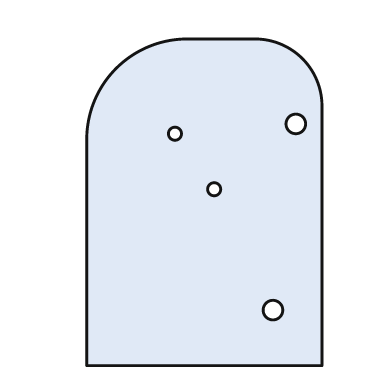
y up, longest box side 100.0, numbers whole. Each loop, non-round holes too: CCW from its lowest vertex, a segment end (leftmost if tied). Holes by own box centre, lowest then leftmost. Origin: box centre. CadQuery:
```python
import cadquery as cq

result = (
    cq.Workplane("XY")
    .moveTo(-36.0, -50.0)
    .lineTo(36.0, -50.0)
    .lineTo(36.0, 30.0)
    .threePointArc((30.0, 44.0), (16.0, 50.0))
    .lineTo(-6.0, 50.0)
    .threePointArc((-27.0, 41.0), (-36.0, 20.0))
    .close()
    .moveTo(21.0, -33.0)
    .circle(3.0)
    .moveTo(3.0, 4.0)
    .circle(2.0)
    .moveTo(-9.0, 21.0)
    .circle(2.0)
    .moveTo(28.0, 24.0)
    .circle(3.0)
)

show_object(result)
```